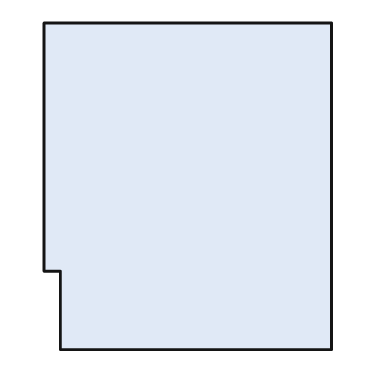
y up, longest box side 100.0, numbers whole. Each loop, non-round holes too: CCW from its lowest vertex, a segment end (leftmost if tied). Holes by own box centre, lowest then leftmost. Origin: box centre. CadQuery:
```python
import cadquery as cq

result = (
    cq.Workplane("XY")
    .moveTo(-39.0, -50.0)
    .lineTo(44.0, -50.0)
    .lineTo(44.0, 50.0)
    .lineTo(-44.0, 50.0)
    .lineTo(-44.0, -26.0)
    .lineTo(-39.0, -26.0)
    .close()
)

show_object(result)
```